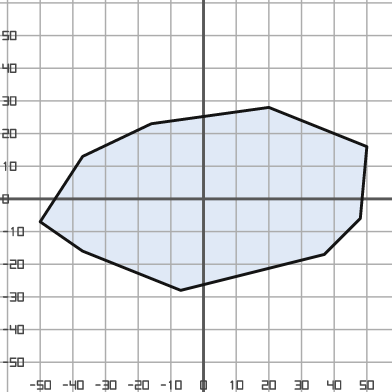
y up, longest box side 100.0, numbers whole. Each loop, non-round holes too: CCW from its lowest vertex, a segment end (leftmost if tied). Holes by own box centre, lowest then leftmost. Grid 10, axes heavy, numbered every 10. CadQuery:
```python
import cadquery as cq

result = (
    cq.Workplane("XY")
    .moveTo(-7.0, -28.0)
    .lineTo(37.0, -17.0)
    .lineTo(48.0, -6.0)
    .lineTo(50.0, 16.0)
    .lineTo(20.0, 28.0)
    .lineTo(-16.0, 23.0)
    .lineTo(-37.0, 13.0)
    .lineTo(-50.0, -7.0)
    .lineTo(-37.0, -16.0)
    .close()
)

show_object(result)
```